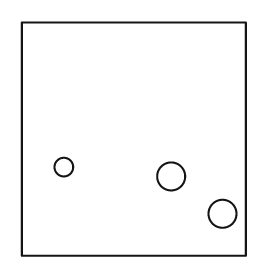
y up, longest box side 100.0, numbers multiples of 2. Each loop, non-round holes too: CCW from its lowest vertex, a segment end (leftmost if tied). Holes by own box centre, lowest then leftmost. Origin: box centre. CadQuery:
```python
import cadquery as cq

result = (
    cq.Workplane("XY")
    .moveTo(-48.0, -50.0)
    .lineTo(48.0, -50.0)
    .lineTo(48.0, 50.0)
    .lineTo(-48.0, 50.0)
    .close()
    .moveTo(38.0, -32.0)
    .circle(6.0)
    .moveTo(16.0, -16.0)
    .circle(6.0)
    .moveTo(-30.0, -12.0)
    .circle(4.0)
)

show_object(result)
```